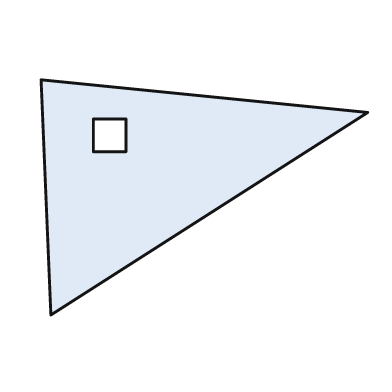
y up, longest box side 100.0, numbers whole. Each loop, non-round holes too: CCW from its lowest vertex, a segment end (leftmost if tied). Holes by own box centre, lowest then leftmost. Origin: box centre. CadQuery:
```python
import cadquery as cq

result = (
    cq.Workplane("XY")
    .moveTo(-47.0, -36.0)
    .lineTo(50.0, 26.0)
    .lineTo(-50.0, 36.0)
    .close()
    .moveTo(-34.0, 14.0)
    .lineTo(-24.0, 14.0)
    .lineTo(-24.0, 24.0)
    .lineTo(-34.0, 24.0)
    .close()
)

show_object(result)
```